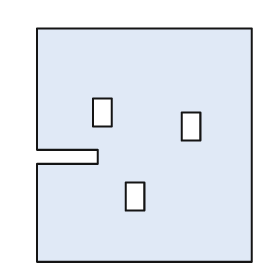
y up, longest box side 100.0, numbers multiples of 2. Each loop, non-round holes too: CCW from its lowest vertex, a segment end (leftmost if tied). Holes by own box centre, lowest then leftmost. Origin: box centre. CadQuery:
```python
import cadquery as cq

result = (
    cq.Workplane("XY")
    .moveTo(-46.0, -50.0)
    .lineTo(46.0, -50.0)
    .lineTo(46.0, 50.0)
    .lineTo(-46.0, 50.0)
    .lineTo(-46.0, -2.0)
    .lineTo(-20.0, -2.0)
    .lineTo(-20.0, -8.0)
    .lineTo(-46.0, -8.0)
    .close()
    .moveTo(-8.0, -28.0)
    .lineTo(0.0, -28.0)
    .lineTo(0.0, -16.0)
    .lineTo(-8.0, -16.0)
    .close()
    .moveTo(16.0, 2.0)
    .lineTo(24.0, 2.0)
    .lineTo(24.0, 14.0)
    .lineTo(16.0, 14.0)
    .close()
    .moveTo(-22.0, 8.0)
    .lineTo(-14.0, 8.0)
    .lineTo(-14.0, 20.0)
    .lineTo(-22.0, 20.0)
    .close()
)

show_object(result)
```